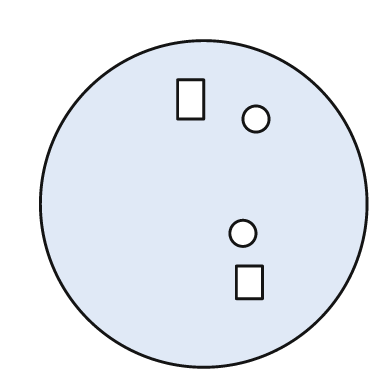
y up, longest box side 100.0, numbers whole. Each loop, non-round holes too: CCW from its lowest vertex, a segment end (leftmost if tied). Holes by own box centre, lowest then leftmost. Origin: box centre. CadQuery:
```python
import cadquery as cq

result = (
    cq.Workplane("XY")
    .moveTo(0.0, 0.0)
    .circle(50.0)
    .moveTo(10.0, -29.0)
    .lineTo(18.0, -29.0)
    .lineTo(18.0, -19.0)
    .lineTo(10.0, -19.0)
    .close()
    .moveTo(12.0, -9.0)
    .circle(4.0)
    .moveTo(16.0, 26.0)
    .circle(4.0)
    .moveTo(-8.0, 26.0)
    .lineTo(0.0, 26.0)
    .lineTo(0.0, 38.0)
    .lineTo(-8.0, 38.0)
    .close()
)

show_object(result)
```